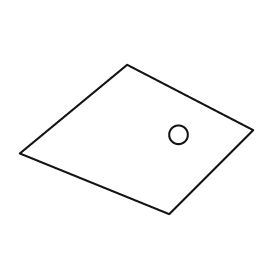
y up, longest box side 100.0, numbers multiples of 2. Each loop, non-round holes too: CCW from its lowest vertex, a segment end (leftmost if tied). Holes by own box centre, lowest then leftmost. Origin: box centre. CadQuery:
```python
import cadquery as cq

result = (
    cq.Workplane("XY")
    .moveTo(14.0, -32.0)
    .lineTo(50.0, 4.0)
    .lineTo(-4.0, 32.0)
    .lineTo(-50.0, -6.0)
    .close()
    .moveTo(18.0, 2.0)
    .circle(4.0)
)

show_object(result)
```